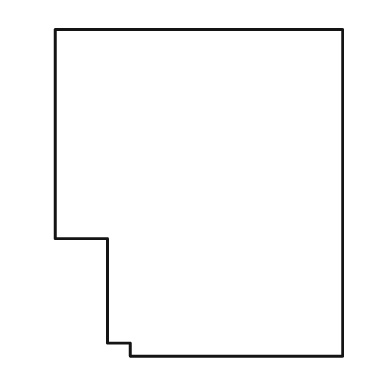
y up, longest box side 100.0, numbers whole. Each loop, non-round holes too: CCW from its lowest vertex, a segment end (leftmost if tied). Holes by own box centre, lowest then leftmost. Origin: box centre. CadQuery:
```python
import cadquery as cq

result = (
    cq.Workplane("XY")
    .moveTo(-21.0, -50.0)
    .lineTo(44.0, -50.0)
    .lineTo(44.0, 50.0)
    .lineTo(-44.0, 50.0)
    .lineTo(-44.0, -14.0)
    .lineTo(-28.0, -14.0)
    .lineTo(-28.0, -46.0)
    .lineTo(-21.0, -46.0)
    .close()
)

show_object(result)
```